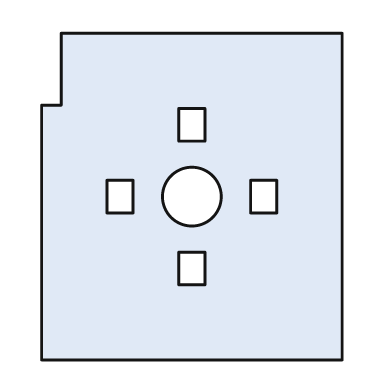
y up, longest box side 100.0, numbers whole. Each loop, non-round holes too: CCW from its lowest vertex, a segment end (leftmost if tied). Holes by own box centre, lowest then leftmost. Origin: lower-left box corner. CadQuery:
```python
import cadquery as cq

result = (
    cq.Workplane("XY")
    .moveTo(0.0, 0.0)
    .lineTo(92.0, 0.0)
    .lineTo(92.0, 100.0)
    .lineTo(6.0, 100.0)
    .lineTo(6.0, 78.0)
    .lineTo(0.0, 78.0)
    .close()
    .moveTo(42.0, 23.0)
    .lineTo(50.0, 23.0)
    .lineTo(50.0, 33.0)
    .lineTo(42.0, 33.0)
    .close()
    .moveTo(20.0, 45.0)
    .lineTo(28.0, 45.0)
    .lineTo(28.0, 55.0)
    .lineTo(20.0, 55.0)
    .close()
    .moveTo(46.0, 50.0)
    .circle(9.0)
    .moveTo(64.0, 45.0)
    .lineTo(72.0, 45.0)
    .lineTo(72.0, 55.0)
    .lineTo(64.0, 55.0)
    .close()
    .moveTo(42.0, 67.0)
    .lineTo(50.0, 67.0)
    .lineTo(50.0, 77.0)
    .lineTo(42.0, 77.0)
    .close()
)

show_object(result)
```